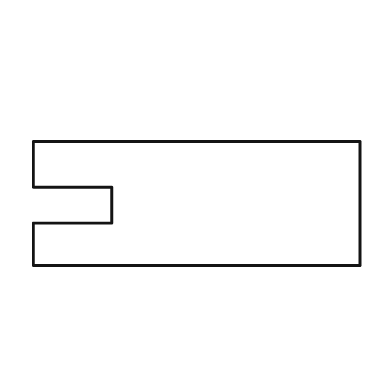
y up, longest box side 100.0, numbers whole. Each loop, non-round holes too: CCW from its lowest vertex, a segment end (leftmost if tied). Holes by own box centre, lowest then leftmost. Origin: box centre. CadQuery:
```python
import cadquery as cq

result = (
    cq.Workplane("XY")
    .moveTo(-50.0, -19.0)
    .lineTo(50.0, -19.0)
    .lineTo(50.0, 19.0)
    .lineTo(-50.0, 19.0)
    .lineTo(-50.0, 5.0)
    .lineTo(-26.0, 5.0)
    .lineTo(-26.0, -6.0)
    .lineTo(-50.0, -6.0)
    .close()
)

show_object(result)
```